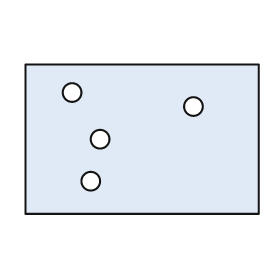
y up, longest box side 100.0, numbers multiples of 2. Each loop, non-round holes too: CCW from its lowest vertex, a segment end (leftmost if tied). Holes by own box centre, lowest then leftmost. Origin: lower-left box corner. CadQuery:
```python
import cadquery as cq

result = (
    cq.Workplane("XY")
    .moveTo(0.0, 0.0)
    .lineTo(100.0, 0.0)
    .lineTo(100.0, 64.0)
    .lineTo(0.0, 64.0)
    .close()
    .moveTo(28.0, 14.0)
    .circle(4.0)
    .moveTo(32.0, 32.0)
    .circle(4.0)
    .moveTo(72.0, 46.0)
    .circle(4.0)
    .moveTo(20.0, 52.0)
    .circle(4.0)
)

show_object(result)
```